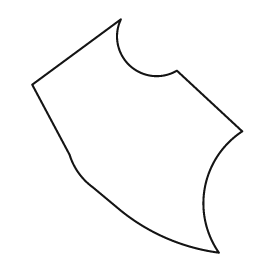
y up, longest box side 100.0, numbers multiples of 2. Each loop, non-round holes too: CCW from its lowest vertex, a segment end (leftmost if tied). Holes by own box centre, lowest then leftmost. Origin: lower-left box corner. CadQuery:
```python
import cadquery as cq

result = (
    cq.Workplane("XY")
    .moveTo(80.0, 0.0)
    .threePointArc((74.0, 28.0), (90.0, 52.0))
    .lineTo(62.0, 78.0)
    .threePointArc((42.0, 80.0), (38.0, 100.0))
    .lineTo(0.0, 72.0)
    .lineTo(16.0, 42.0)
    .threePointArc((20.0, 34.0), (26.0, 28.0))
    .lineTo(38.0, 18.0)
    .threePointArc((58.0, 6.0), (80.0, 0.0))
    .close()
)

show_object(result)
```